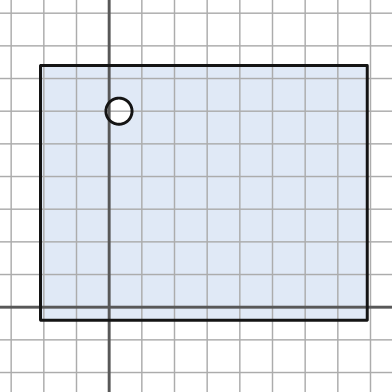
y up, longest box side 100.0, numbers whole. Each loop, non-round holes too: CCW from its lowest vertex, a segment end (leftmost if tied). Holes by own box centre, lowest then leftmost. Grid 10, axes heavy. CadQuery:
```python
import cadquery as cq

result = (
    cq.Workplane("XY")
    .moveTo(-21.0, -4.0)
    .lineTo(79.0, -4.0)
    .lineTo(79.0, 74.0)
    .lineTo(-21.0, 74.0)
    .close()
    .moveTo(3.0, 60.0)
    .circle(4.0)
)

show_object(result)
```